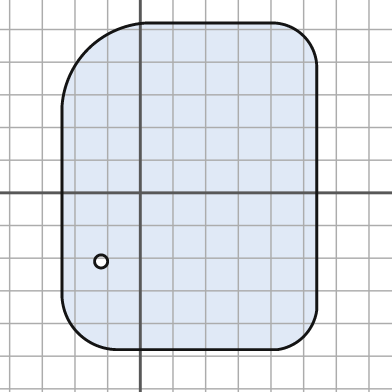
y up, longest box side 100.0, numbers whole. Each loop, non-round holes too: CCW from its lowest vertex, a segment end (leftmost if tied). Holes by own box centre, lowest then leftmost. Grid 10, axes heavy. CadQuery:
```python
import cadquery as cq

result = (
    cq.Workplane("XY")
    .moveTo(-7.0, -48.0)
    .lineTo(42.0, -48.0)
    .threePointArc((50.0, -44.0), (54.0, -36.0))
    .lineTo(54.0, 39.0)
    .threePointArc((50.0, 48.0), (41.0, 52.0))
    .lineTo(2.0, 52.0)
    .threePointArc((-16.0, 44.0), (-24.0, 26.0))
    .lineTo(-24.0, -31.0)
    .threePointArc((-19.0, -43.0), (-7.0, -48.0))
    .close()
    .moveTo(-12.0, -21.0)
    .circle(2.0)
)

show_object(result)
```